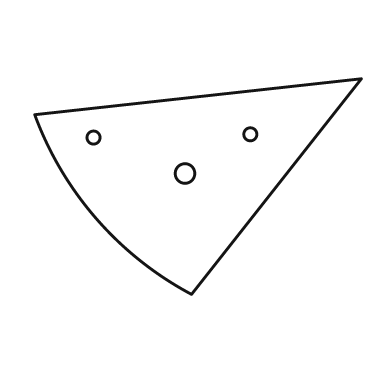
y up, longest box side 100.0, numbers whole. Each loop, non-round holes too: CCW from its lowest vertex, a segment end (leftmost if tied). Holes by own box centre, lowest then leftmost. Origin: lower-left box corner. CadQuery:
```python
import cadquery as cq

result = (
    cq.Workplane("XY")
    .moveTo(48.0, 0.0)
    .lineTo(100.0, 66.0)
    .lineTo(0.0, 55.0)
    .threePointArc((19.0, 23.0), (48.0, 0.0))
    .close()
    .moveTo(46.0, 37.0)
    .circle(3.0)
    .moveTo(18.0, 48.0)
    .circle(2.0)
    .moveTo(66.0, 49.0)
    .circle(2.0)
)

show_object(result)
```